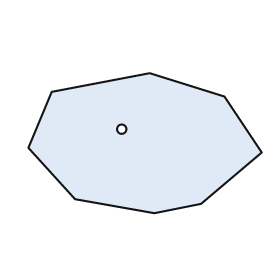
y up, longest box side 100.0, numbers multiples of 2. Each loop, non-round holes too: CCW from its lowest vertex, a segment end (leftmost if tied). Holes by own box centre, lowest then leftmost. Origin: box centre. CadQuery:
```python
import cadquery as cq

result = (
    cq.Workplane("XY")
    .moveTo(4.0, -30.0)
    .lineTo(24.0, -26.0)
    .lineTo(50.0, -4.0)
    .lineTo(34.0, 20.0)
    .lineTo(2.0, 30.0)
    .lineTo(-40.0, 22.0)
    .lineTo(-50.0, -2.0)
    .lineTo(-30.0, -24.0)
    .close()
    .moveTo(-10.0, 6.0)
    .circle(2.0)
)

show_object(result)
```